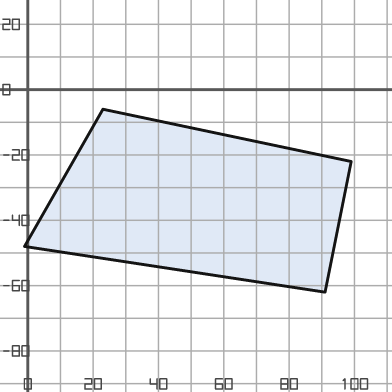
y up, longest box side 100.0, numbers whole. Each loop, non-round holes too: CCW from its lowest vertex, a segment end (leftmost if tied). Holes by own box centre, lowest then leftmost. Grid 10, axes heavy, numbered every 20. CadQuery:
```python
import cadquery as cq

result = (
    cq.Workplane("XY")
    .moveTo(91.0, -62.0)
    .lineTo(99.0, -22.0)
    .lineTo(23.0, -6.0)
    .lineTo(-1.0, -48.0)
    .close()
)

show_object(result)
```